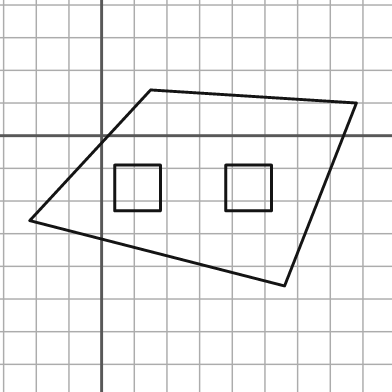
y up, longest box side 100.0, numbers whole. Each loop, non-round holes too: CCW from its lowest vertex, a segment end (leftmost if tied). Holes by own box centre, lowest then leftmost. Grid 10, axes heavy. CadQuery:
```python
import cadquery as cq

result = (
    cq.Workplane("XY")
    .moveTo(56.0, -46.0)
    .lineTo(78.0, 10.0)
    .lineTo(15.0, 14.0)
    .lineTo(-22.0, -26.0)
    .close()
    .moveTo(4.0, -23.0)
    .lineTo(18.0, -23.0)
    .lineTo(18.0, -9.0)
    .lineTo(4.0, -9.0)
    .close()
    .moveTo(38.0, -23.0)
    .lineTo(52.0, -23.0)
    .lineTo(52.0, -9.0)
    .lineTo(38.0, -9.0)
    .close()
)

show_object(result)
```